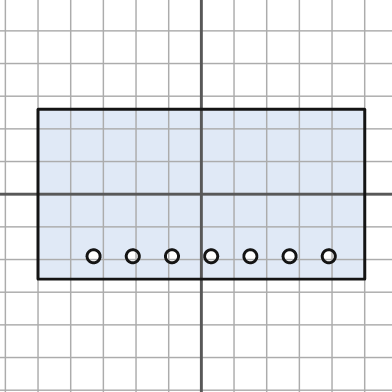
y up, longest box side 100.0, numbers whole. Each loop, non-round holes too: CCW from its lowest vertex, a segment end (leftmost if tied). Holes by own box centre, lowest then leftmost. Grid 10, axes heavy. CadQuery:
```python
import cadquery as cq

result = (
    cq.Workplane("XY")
    .moveTo(-50.0, -26.0)
    .lineTo(50.0, -26.0)
    .lineTo(50.0, 26.0)
    .lineTo(-50.0, 26.0)
    .close()
    .moveTo(-33.0, -19.0)
    .circle(2.0)
    .moveTo(-21.0, -19.0)
    .circle(2.0)
    .moveTo(-9.0, -19.0)
    .circle(2.0)
    .moveTo(3.0, -19.0)
    .circle(2.0)
    .moveTo(15.0, -19.0)
    .circle(2.0)
    .moveTo(27.0, -19.0)
    .circle(2.0)
    .moveTo(39.0, -19.0)
    .circle(2.0)
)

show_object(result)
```